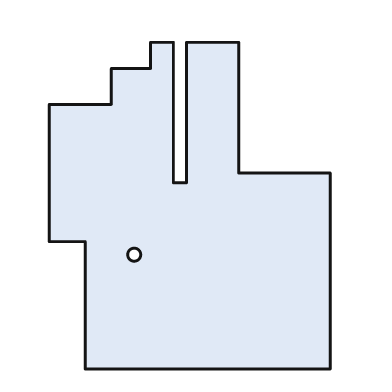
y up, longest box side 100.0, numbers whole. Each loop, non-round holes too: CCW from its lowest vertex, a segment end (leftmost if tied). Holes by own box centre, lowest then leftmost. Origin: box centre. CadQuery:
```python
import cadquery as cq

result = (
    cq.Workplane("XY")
    .moveTo(-32.0, -50.0)
    .lineTo(43.0, -50.0)
    .lineTo(43.0, 10.0)
    .lineTo(15.0, 10.0)
    .lineTo(15.0, 50.0)
    .lineTo(-1.0, 50.0)
    .lineTo(-1.0, 7.0)
    .lineTo(-5.0, 7.0)
    .lineTo(-5.0, 50.0)
    .lineTo(-12.0, 50.0)
    .lineTo(-12.0, 42.0)
    .lineTo(-24.0, 42.0)
    .lineTo(-24.0, 31.0)
    .lineTo(-43.0, 31.0)
    .lineTo(-43.0, -11.0)
    .lineTo(-32.0, -11.0)
    .close()
    .moveTo(-17.0, -15.0)
    .circle(2.0)
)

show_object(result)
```